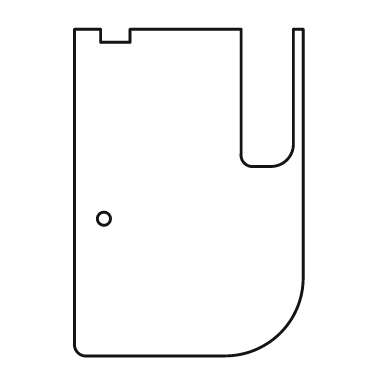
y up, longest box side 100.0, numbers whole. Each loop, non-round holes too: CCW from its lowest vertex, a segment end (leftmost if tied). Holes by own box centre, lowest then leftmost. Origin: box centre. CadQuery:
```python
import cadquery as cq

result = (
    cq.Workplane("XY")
    .moveTo(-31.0, -50.0)
    .lineTo(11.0, -50.0)
    .threePointArc((28.0, -43.0), (35.0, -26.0))
    .lineTo(35.0, 50.0)
    .lineTo(32.0, 50.0)
    .lineTo(32.0, 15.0)
    .threePointArc((30.0, 10.0), (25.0, 8.0))
    .lineTo(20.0, 8.0)
    .threePointArc((17.0, 9.0), (16.0, 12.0))
    .lineTo(16.0, 50.0)
    .lineTo(-18.0, 50.0)
    .lineTo(-18.0, 46.0)
    .lineTo(-27.0, 46.0)
    .lineTo(-27.0, 50.0)
    .lineTo(-35.0, 50.0)
    .lineTo(-35.0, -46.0)
    .threePointArc((-34.0, -49.0), (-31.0, -50.0))
    .close()
    .moveTo(-26.0, -8.0)
    .circle(2.0)
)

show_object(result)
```